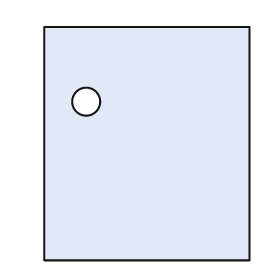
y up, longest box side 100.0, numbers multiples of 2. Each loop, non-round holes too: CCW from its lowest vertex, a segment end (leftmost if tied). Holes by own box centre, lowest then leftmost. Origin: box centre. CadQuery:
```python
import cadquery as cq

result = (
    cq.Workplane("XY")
    .moveTo(-44.0, -50.0)
    .lineTo(44.0, -50.0)
    .lineTo(44.0, 50.0)
    .lineTo(-44.0, 50.0)
    .close()
    .moveTo(-26.0, 18.0)
    .circle(6.0)
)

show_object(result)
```